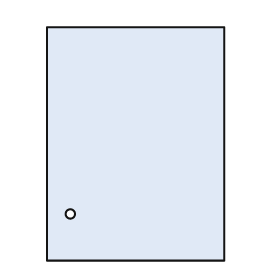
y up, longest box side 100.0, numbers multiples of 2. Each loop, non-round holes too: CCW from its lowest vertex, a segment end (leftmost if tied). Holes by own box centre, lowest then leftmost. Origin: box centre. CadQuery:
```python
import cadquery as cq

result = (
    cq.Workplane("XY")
    .moveTo(-38.0, -50.0)
    .lineTo(38.0, -50.0)
    .lineTo(38.0, 50.0)
    .lineTo(-38.0, 50.0)
    .close()
    .moveTo(-28.0, -30.0)
    .circle(2.0)
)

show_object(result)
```